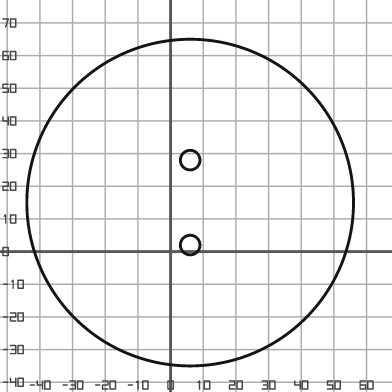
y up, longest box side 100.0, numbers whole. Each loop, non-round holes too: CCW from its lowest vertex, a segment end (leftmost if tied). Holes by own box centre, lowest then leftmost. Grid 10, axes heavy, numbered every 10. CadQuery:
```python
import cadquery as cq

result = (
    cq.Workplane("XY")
    .moveTo(6.0, 15.0)
    .circle(50.0)
    .moveTo(6.0, 2.0)
    .circle(3.0)
    .moveTo(6.0, 28.0)
    .circle(3.0)
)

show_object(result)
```